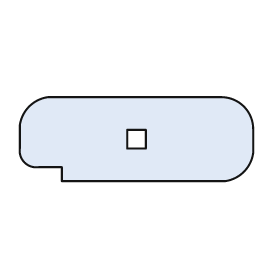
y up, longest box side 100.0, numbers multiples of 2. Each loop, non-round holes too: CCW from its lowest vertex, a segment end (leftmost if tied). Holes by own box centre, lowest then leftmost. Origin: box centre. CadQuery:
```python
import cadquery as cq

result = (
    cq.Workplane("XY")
    .moveTo(-32.0, -18.0)
    .lineTo(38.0, -18.0)
    .threePointArc((46.0, -14.0), (50.0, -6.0))
    .lineTo(50.0, 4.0)
    .threePointArc((46.0, 14.0), (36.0, 18.0))
    .lineTo(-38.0, 18.0)
    .threePointArc((-46.0, 14.0), (-50.0, 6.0))
    .lineTo(-50.0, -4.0)
    .threePointArc((-48.0, -10.0), (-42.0, -12.0))
    .lineTo(-32.0, -12.0)
    .close()
    .moveTo(-4.0, -4.0)
    .lineTo(4.0, -4.0)
    .lineTo(4.0, 4.0)
    .lineTo(-4.0, 4.0)
    .close()
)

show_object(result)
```